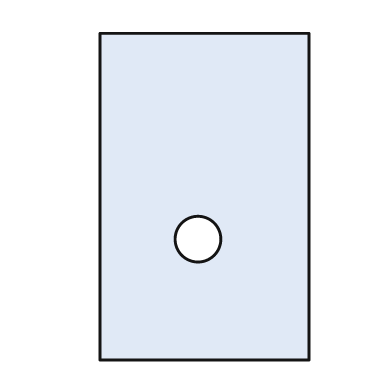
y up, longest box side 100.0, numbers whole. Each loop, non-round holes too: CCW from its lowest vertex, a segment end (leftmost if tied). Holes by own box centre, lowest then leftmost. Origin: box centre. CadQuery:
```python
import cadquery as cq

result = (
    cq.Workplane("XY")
    .moveTo(-32.0, -50.0)
    .lineTo(32.0, -50.0)
    .lineTo(32.0, 50.0)
    .lineTo(-32.0, 50.0)
    .close()
    .moveTo(-2.0, -13.0)
    .circle(7.0)
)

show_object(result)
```